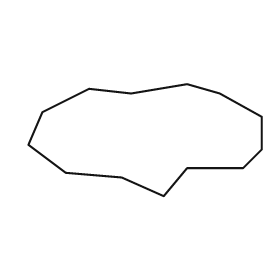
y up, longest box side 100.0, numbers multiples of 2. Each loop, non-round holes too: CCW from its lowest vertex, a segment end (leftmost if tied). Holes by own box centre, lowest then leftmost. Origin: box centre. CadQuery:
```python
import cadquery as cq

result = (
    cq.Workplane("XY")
    .moveTo(8.0, -24.0)
    .lineTo(18.0, -12.0)
    .lineTo(42.0, -12.0)
    .lineTo(50.0, -4.0)
    .lineTo(50.0, 10.0)
    .lineTo(32.0, 20.0)
    .lineTo(18.0, 24.0)
    .lineTo(-6.0, 20.0)
    .lineTo(-24.0, 22.0)
    .lineTo(-44.0, 12.0)
    .lineTo(-50.0, -2.0)
    .lineTo(-34.0, -14.0)
    .lineTo(-10.0, -16.0)
    .close()
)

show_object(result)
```